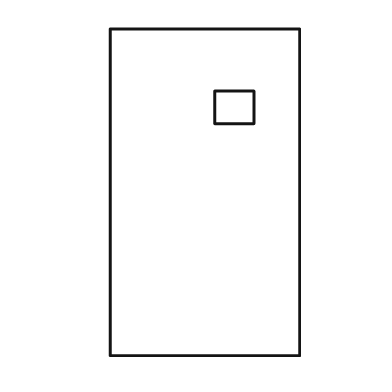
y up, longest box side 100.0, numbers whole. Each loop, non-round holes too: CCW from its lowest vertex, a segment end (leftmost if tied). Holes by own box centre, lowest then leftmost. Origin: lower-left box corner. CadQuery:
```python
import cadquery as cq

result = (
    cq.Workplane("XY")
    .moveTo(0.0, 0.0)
    .lineTo(58.0, 0.0)
    .lineTo(58.0, 100.0)
    .lineTo(0.0, 100.0)
    .close()
    .moveTo(32.0, 71.0)
    .lineTo(44.0, 71.0)
    .lineTo(44.0, 81.0)
    .lineTo(32.0, 81.0)
    .close()
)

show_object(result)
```